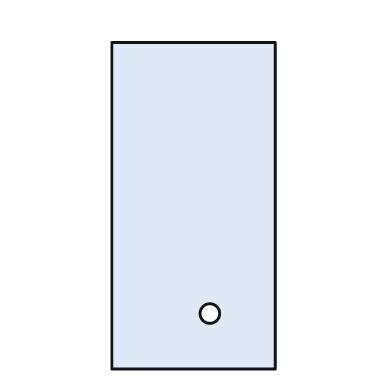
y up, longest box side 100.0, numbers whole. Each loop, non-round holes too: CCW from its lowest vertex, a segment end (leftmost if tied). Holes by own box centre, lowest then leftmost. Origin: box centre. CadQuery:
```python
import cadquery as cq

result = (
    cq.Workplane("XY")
    .moveTo(-25.0, -50.0)
    .lineTo(25.0, -50.0)
    .lineTo(25.0, 50.0)
    .lineTo(-25.0, 50.0)
    .close()
    .moveTo(5.0, -33.0)
    .circle(3.0)
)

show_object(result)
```